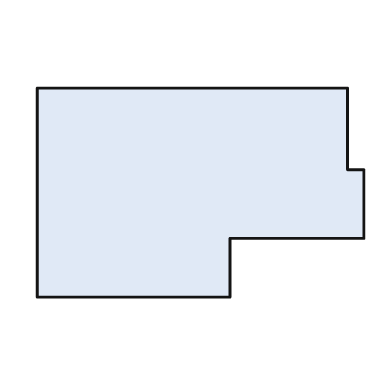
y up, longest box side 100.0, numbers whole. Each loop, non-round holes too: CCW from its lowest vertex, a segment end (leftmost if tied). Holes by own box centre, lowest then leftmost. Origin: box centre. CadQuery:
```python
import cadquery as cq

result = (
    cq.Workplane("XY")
    .moveTo(-50.0, -32.0)
    .lineTo(9.0, -32.0)
    .lineTo(9.0, -14.0)
    .lineTo(50.0, -14.0)
    .lineTo(50.0, 7.0)
    .lineTo(45.0, 7.0)
    .lineTo(45.0, 32.0)
    .lineTo(-50.0, 32.0)
    .close()
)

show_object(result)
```